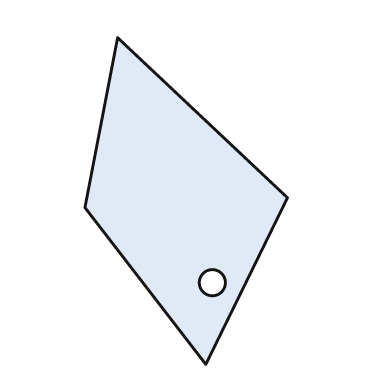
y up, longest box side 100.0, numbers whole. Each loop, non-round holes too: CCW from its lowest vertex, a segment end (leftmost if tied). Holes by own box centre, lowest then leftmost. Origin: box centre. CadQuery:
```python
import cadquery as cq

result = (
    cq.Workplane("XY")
    .moveTo(6.0, -50.0)
    .lineTo(31.0, 1.0)
    .lineTo(-21.0, 50.0)
    .lineTo(-31.0, -2.0)
    .close()
    .moveTo(8.0, -25.0)
    .circle(4.0)
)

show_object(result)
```